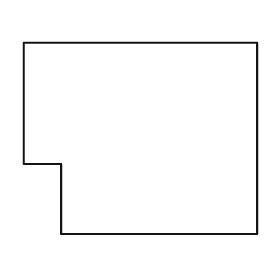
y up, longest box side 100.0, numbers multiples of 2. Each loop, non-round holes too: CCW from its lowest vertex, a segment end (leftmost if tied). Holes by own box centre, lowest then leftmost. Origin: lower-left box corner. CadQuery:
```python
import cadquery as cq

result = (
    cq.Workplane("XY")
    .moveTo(16.0, 0.0)
    .lineTo(100.0, 0.0)
    .lineTo(100.0, 82.0)
    .lineTo(0.0, 82.0)
    .lineTo(0.0, 30.0)
    .lineTo(16.0, 30.0)
    .close()
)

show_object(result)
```